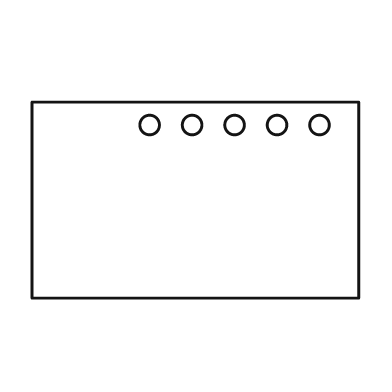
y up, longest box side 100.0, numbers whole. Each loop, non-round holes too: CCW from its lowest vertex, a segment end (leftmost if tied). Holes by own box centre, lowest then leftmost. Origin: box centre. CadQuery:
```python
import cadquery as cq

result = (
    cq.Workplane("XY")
    .moveTo(-50.0, -30.0)
    .lineTo(50.0, -30.0)
    .lineTo(50.0, 30.0)
    .lineTo(-50.0, 30.0)
    .close()
    .moveTo(-14.0, 23.0)
    .circle(3.0)
    .moveTo(-1.0, 23.0)
    .circle(3.0)
    .moveTo(12.0, 23.0)
    .circle(3.0)
    .moveTo(25.0, 23.0)
    .circle(3.0)
    .moveTo(38.0, 23.0)
    .circle(3.0)
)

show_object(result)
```